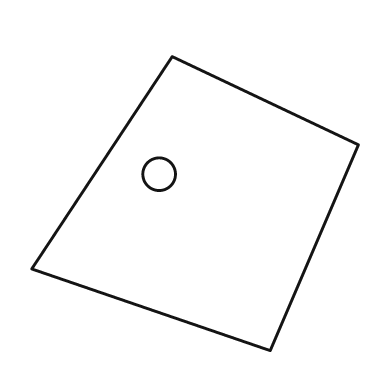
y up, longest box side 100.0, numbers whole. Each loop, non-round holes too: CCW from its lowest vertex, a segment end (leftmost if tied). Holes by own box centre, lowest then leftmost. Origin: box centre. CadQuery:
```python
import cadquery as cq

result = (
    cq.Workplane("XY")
    .moveTo(23.0, -45.0)
    .lineTo(50.0, 18.0)
    .lineTo(-7.0, 45.0)
    .lineTo(-50.0, -20.0)
    .close()
    .moveTo(-11.0, 9.0)
    .circle(5.0)
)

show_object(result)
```